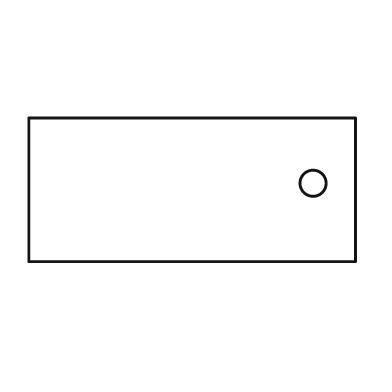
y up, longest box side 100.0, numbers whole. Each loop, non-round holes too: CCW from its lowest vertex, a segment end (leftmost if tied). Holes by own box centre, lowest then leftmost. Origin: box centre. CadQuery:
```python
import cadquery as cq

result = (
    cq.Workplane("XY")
    .moveTo(-50.0, -22.0)
    .lineTo(50.0, -22.0)
    .lineTo(50.0, 22.0)
    .lineTo(-50.0, 22.0)
    .close()
    .moveTo(37.0, 2.0)
    .circle(4.0)
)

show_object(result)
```